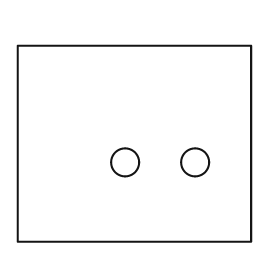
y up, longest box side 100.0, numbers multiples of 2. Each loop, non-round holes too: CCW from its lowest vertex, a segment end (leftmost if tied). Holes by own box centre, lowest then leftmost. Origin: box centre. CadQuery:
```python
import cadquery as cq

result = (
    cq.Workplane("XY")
    .moveTo(-50.0, -42.0)
    .lineTo(50.0, -42.0)
    .lineTo(50.0, 42.0)
    .lineTo(-50.0, 42.0)
    .close()
    .moveTo(-4.0, -8.0)
    .circle(6.0)
    .moveTo(26.0, -8.0)
    .circle(6.0)
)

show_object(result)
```